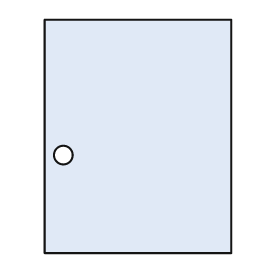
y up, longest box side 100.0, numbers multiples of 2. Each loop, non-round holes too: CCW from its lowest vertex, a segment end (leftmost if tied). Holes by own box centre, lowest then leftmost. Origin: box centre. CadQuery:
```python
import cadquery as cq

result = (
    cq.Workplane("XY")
    .moveTo(-40.0, -50.0)
    .lineTo(40.0, -50.0)
    .lineTo(40.0, 50.0)
    .lineTo(-40.0, 50.0)
    .close()
    .moveTo(-32.0, -8.0)
    .circle(4.0)
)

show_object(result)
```